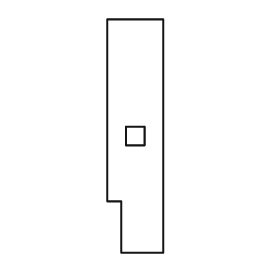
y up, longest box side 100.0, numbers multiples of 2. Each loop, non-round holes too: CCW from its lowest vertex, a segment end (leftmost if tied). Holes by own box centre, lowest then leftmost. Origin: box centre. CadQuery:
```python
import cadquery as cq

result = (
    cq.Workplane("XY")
    .moveTo(-6.0, -50.0)
    .lineTo(12.0, -50.0)
    .lineTo(12.0, 50.0)
    .lineTo(-12.0, 50.0)
    .lineTo(-12.0, -28.0)
    .lineTo(-6.0, -28.0)
    .close()
    .moveTo(-4.0, -4.0)
    .lineTo(4.0, -4.0)
    .lineTo(4.0, 4.0)
    .lineTo(-4.0, 4.0)
    .close()
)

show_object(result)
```